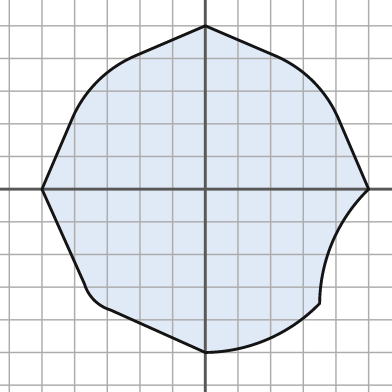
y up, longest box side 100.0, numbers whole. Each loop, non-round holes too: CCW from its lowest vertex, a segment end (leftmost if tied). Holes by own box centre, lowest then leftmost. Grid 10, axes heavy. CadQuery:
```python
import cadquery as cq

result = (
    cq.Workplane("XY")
    .moveTo(0.0, -50.0)
    .threePointArc((19.0, -46.0), (35.0, -35.0))
    .threePointArc((39.0, -16.0), (50.0, 0.0))
    .lineTo(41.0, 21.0)
    .threePointArc((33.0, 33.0), (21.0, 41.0))
    .lineTo(0.0, 50.0)
    .lineTo(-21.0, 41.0)
    .threePointArc((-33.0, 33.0), (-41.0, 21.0))
    .lineTo(-50.0, 0.0)
    .lineTo(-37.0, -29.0)
    .threePointArc((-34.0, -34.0), (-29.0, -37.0))
    .close()
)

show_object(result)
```